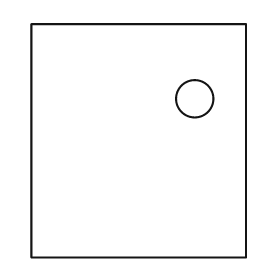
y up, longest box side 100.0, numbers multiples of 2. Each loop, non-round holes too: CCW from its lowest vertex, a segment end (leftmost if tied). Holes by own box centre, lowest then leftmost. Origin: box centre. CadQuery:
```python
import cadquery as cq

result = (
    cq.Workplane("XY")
    .moveTo(-46.0, -50.0)
    .lineTo(46.0, -50.0)
    .lineTo(46.0, 50.0)
    .lineTo(-46.0, 50.0)
    .close()
    .moveTo(24.0, 18.0)
    .circle(8.0)
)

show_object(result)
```